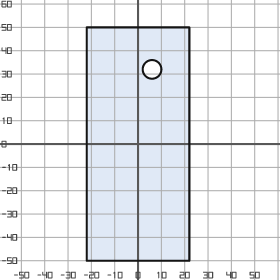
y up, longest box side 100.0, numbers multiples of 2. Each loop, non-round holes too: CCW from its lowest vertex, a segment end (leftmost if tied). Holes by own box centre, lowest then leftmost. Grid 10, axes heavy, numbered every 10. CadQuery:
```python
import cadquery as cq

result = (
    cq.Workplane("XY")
    .moveTo(-22.0, -50.0)
    .lineTo(22.0, -50.0)
    .lineTo(22.0, 50.0)
    .lineTo(-22.0, 50.0)
    .close()
    .moveTo(6.0, 32.0)
    .circle(4.0)
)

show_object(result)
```